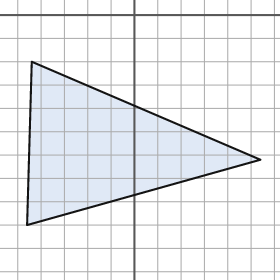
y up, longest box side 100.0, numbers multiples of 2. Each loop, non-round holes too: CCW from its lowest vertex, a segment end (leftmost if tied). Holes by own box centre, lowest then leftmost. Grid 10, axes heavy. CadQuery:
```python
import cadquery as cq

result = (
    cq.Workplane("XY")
    .moveTo(-46.0, -90.0)
    .lineTo(54.0, -62.0)
    .lineTo(-44.0, -20.0)
    .close()
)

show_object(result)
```